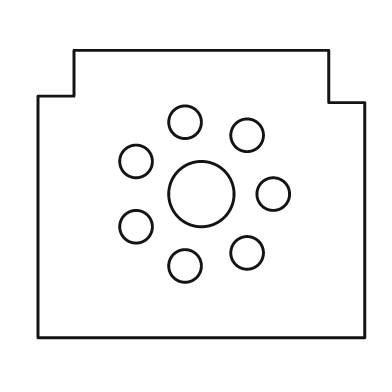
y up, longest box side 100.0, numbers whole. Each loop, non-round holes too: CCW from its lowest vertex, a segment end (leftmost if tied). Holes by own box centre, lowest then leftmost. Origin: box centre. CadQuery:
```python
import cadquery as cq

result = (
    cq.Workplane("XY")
    .moveTo(-50.0, -44.0)
    .lineTo(50.0, -44.0)
    .lineTo(50.0, 28.0)
    .lineTo(39.0, 28.0)
    .lineTo(39.0, 44.0)
    .lineTo(-39.0, 44.0)
    .lineTo(-39.0, 30.0)
    .lineTo(-50.0, 30.0)
    .close()
    .moveTo(-5.0, -22.0)
    .circle(5.0)
    .moveTo(14.0, -18.0)
    .circle(5.0)
    .moveTo(-20.0, -10.0)
    .circle(5.0)
    .moveTo(0.0, 0.0)
    .circle(10.0)
    .moveTo(22.0, 0.0)
    .circle(5.0)
    .moveTo(-20.0, 10.0)
    .circle(5.0)
    .moveTo(14.0, 18.0)
    .circle(5.0)
    .moveTo(-5.0, 22.0)
    .circle(5.0)
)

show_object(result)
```